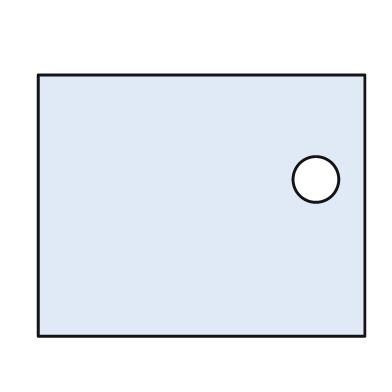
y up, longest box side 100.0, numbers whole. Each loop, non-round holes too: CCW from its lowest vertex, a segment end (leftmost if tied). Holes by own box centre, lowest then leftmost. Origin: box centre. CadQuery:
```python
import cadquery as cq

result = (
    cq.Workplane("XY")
    .moveTo(-50.0, -40.0)
    .lineTo(50.0, -40.0)
    .lineTo(50.0, 40.0)
    .lineTo(-50.0, 40.0)
    .close()
    .moveTo(35.0, 8.0)
    .circle(7.0)
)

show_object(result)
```